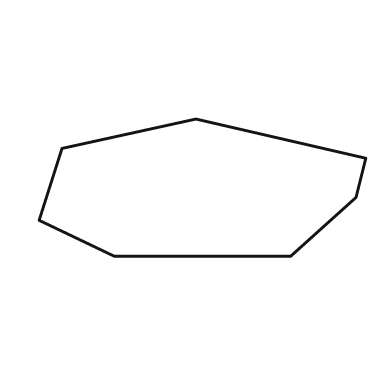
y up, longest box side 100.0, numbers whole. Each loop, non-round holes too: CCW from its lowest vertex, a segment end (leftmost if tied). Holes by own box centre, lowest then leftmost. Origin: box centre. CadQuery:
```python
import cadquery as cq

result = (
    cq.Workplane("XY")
    .moveTo(-27.0, -21.0)
    .lineTo(27.0, -21.0)
    .lineTo(47.0, -3.0)
    .lineTo(50.0, 9.0)
    .lineTo(-2.0, 21.0)
    .lineTo(-43.0, 12.0)
    .lineTo(-50.0, -10.0)
    .close()
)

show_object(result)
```